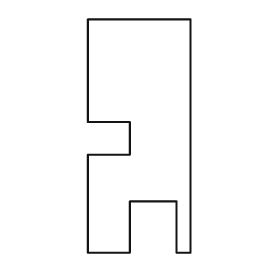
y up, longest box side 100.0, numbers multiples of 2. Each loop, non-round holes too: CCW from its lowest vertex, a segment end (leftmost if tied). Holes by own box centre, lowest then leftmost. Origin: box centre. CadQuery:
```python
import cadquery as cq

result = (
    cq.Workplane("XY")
    .moveTo(-22.0, -50.0)
    .lineTo(-4.0, -50.0)
    .lineTo(-4.0, -28.0)
    .lineTo(16.0, -28.0)
    .lineTo(16.0, -50.0)
    .lineTo(22.0, -50.0)
    .lineTo(22.0, 50.0)
    .lineTo(-22.0, 50.0)
    .lineTo(-22.0, 6.0)
    .lineTo(-4.0, 6.0)
    .lineTo(-4.0, -8.0)
    .lineTo(-22.0, -8.0)
    .close()
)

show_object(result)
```